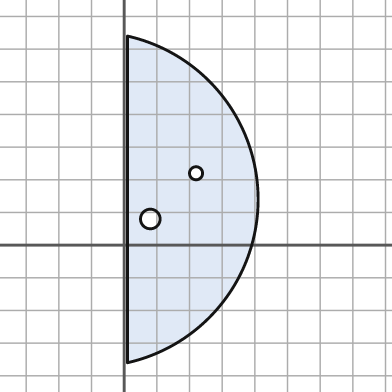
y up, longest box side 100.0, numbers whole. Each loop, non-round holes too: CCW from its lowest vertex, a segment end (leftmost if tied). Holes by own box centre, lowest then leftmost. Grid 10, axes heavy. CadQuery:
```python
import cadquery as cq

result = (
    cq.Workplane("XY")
    .moveTo(1.0, -36.0)
    .threePointArc((41.0, 14.0), (1.0, 64.0))
    .close()
    .moveTo(8.0, 8.0)
    .circle(3.0)
    .moveTo(22.0, 22.0)
    .circle(2.0)
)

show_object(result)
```